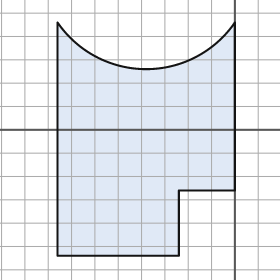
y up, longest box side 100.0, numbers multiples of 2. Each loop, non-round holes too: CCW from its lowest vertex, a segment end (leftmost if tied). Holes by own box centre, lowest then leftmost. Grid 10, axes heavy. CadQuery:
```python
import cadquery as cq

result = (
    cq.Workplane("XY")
    .moveTo(-76.0, -54.0)
    .lineTo(-24.0, -54.0)
    .lineTo(-24.0, -26.0)
    .lineTo(0.0, -26.0)
    .lineTo(0.0, 46.0)
    .threePointArc((-38.0, 26.0), (-76.0, 46.0))
    .close()
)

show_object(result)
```